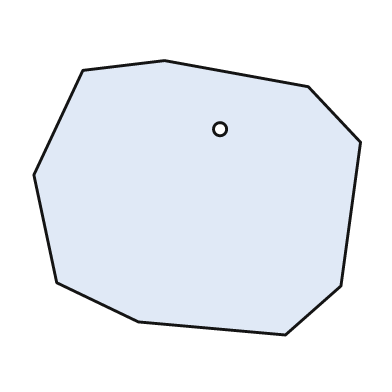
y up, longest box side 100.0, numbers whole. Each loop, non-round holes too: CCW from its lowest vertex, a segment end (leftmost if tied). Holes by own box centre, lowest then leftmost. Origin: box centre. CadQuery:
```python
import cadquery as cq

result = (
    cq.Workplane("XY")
    .moveTo(27.0, -42.0)
    .lineTo(44.0, -27.0)
    .lineTo(50.0, 17.0)
    .lineTo(34.0, 34.0)
    .lineTo(-10.0, 42.0)
    .lineTo(-35.0, 39.0)
    .lineTo(-50.0, 7.0)
    .lineTo(-43.0, -26.0)
    .lineTo(-18.0, -38.0)
    .close()
    .moveTo(7.0, 21.0)
    .circle(2.0)
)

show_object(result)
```